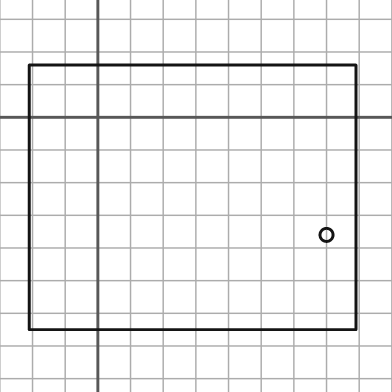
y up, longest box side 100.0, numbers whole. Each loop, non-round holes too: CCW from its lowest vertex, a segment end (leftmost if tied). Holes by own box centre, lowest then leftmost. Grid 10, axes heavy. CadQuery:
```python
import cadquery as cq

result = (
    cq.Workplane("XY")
    .moveTo(-21.0, -65.0)
    .lineTo(79.0, -65.0)
    .lineTo(79.0, 16.0)
    .lineTo(-21.0, 16.0)
    .close()
    .moveTo(70.0, -36.0)
    .circle(2.0)
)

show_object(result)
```